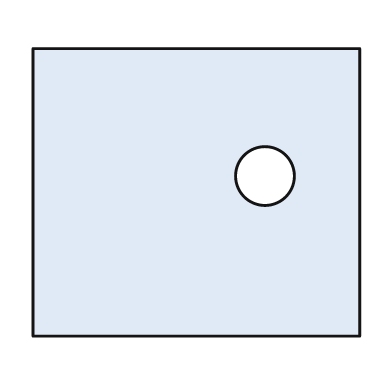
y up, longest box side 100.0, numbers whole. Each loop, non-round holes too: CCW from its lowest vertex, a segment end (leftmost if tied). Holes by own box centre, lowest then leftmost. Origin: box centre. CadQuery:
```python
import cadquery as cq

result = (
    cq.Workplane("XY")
    .moveTo(-50.0, -44.0)
    .lineTo(50.0, -44.0)
    .lineTo(50.0, 44.0)
    .lineTo(-50.0, 44.0)
    .close()
    .moveTo(21.0, 5.0)
    .circle(9.0)
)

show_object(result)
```